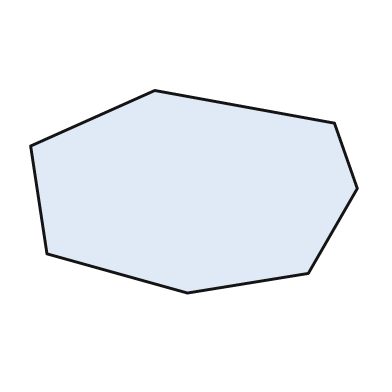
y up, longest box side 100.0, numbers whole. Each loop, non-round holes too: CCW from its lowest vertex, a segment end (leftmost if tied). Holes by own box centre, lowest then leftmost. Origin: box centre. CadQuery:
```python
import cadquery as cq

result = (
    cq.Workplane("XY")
    .moveTo(-2.0, -31.0)
    .lineTo(35.0, -25.0)
    .lineTo(50.0, 1.0)
    .lineTo(43.0, 21.0)
    .lineTo(-12.0, 31.0)
    .lineTo(-50.0, 14.0)
    .lineTo(-45.0, -19.0)
    .close()
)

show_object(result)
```